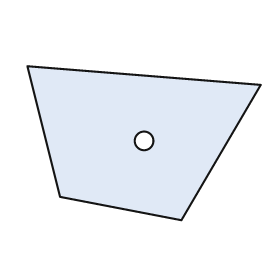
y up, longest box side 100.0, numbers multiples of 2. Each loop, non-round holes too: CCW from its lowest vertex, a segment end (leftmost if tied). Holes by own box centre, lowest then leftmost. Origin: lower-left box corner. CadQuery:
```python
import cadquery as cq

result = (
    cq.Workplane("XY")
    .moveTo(66.0, 0.0)
    .lineTo(100.0, 58.0)
    .lineTo(0.0, 66.0)
    .lineTo(14.0, 10.0)
    .close()
    .moveTo(50.0, 34.0)
    .circle(4.0)
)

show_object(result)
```